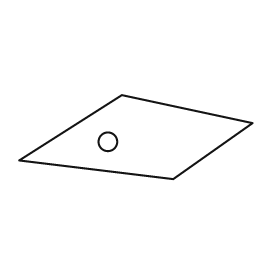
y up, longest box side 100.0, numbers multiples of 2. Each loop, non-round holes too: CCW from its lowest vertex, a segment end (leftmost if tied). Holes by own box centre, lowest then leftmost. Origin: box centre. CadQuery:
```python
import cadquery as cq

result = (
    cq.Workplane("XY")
    .moveTo(16.0, -18.0)
    .lineTo(50.0, 6.0)
    .lineTo(-6.0, 18.0)
    .lineTo(-50.0, -10.0)
    .close()
    .moveTo(-12.0, -2.0)
    .circle(4.0)
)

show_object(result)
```